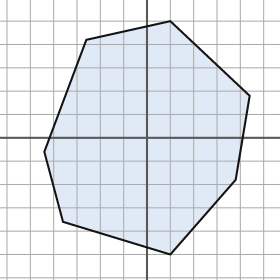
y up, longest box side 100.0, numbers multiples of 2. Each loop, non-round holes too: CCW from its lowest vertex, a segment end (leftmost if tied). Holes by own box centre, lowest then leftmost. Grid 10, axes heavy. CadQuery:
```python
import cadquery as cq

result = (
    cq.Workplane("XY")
    .moveTo(10.0, -50.0)
    .lineTo(38.0, -18.0)
    .lineTo(44.0, 18.0)
    .lineTo(10.0, 50.0)
    .lineTo(-26.0, 42.0)
    .lineTo(-44.0, -6.0)
    .lineTo(-36.0, -36.0)
    .close()
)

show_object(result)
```